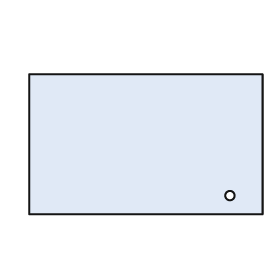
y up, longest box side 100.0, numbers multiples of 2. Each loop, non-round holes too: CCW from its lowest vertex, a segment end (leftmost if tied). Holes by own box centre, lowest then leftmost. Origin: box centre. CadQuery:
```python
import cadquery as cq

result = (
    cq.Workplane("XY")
    .moveTo(-50.0, -30.0)
    .lineTo(50.0, -30.0)
    .lineTo(50.0, 30.0)
    .lineTo(-50.0, 30.0)
    .close()
    .moveTo(36.0, -22.0)
    .circle(2.0)
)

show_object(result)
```